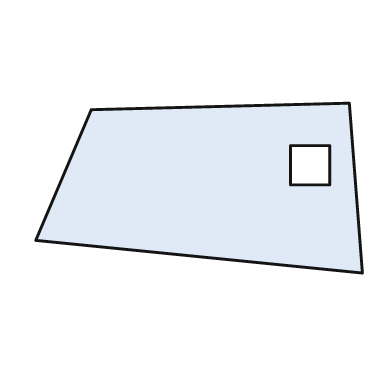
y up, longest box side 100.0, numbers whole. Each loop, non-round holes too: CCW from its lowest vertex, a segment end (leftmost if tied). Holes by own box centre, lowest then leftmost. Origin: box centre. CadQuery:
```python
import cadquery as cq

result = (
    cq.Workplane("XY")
    .moveTo(50.0, -26.0)
    .lineTo(46.0, 26.0)
    .lineTo(-33.0, 24.0)
    .lineTo(-50.0, -16.0)
    .close()
    .moveTo(28.0, 1.0)
    .lineTo(40.0, 1.0)
    .lineTo(40.0, 13.0)
    .lineTo(28.0, 13.0)
    .close()
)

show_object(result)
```